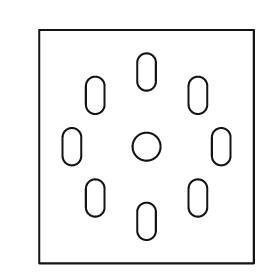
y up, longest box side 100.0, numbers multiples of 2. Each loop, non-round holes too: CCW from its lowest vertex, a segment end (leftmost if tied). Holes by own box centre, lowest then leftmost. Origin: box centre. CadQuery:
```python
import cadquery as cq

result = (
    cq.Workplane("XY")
    .moveTo(-46.0, -50.0)
    .lineTo(46.0, -50.0)
    .lineTo(46.0, 50.0)
    .lineTo(-46.0, 50.0)
    .close()
    .moveTo(-4.0, -36.0)
    .threePointArc((0.0, -40.0), (4.0, -36.0))
    .lineTo(4.0, -28.0)
    .threePointArc((0.0, -24.0), (-4.0, -28.0))
    .close()
    .moveTo(-26.0, -26.0)
    .threePointArc((-22.0, -30.0), (-18.0, -26.0))
    .lineTo(-18.0, -18.0)
    .threePointArc((-22.0, -14.0), (-26.0, -18.0))
    .close()
    .moveTo(18.0, -26.0)
    .threePointArc((22.0, -30.0), (26.0, -26.0))
    .lineTo(26.0, -18.0)
    .threePointArc((22.0, -14.0), (18.0, -18.0))
    .close()
    .moveTo(-36.0, -4.0)
    .threePointArc((-32.0, -8.0), (-28.0, -4.0))
    .lineTo(-28.0, 4.0)
    .threePointArc((-32.0, 8.0), (-36.0, 4.0))
    .close()
    .moveTo(0.0, 0.0)
    .circle(6.0)
    .moveTo(28.0, -4.0)
    .threePointArc((32.0, -8.0), (36.0, -4.0))
    .lineTo(36.0, 4.0)
    .threePointArc((32.0, 8.0), (28.0, 4.0))
    .close()
    .moveTo(-26.0, 18.0)
    .threePointArc((-22.0, 14.0), (-18.0, 18.0))
    .lineTo(-18.0, 26.0)
    .threePointArc((-22.0, 30.0), (-26.0, 26.0))
    .close()
    .moveTo(18.0, 18.0)
    .threePointArc((22.0, 14.0), (26.0, 18.0))
    .lineTo(26.0, 26.0)
    .threePointArc((22.0, 30.0), (18.0, 26.0))
    .close()
    .moveTo(-4.0, 28.0)
    .threePointArc((0.0, 24.0), (4.0, 28.0))
    .lineTo(4.0, 36.0)
    .threePointArc((0.0, 40.0), (-4.0, 36.0))
    .close()
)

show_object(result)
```